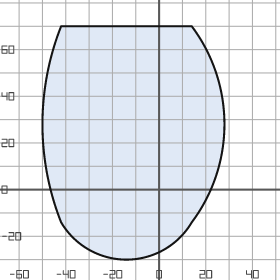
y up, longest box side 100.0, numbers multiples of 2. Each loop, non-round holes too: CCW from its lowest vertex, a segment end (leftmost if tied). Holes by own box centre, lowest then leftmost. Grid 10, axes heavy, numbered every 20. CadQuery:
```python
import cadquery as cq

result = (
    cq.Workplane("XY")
    .moveTo(-42.0, -14.0)
    .threePointArc((-14.0, -30.0), (14.0, -14.0))
    .threePointArc((28.0, 28.0), (14.0, 70.0))
    .lineTo(-42.0, 70.0)
    .threePointArc((-50.0, 28.0), (-42.0, -14.0))
    .close()
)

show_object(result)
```